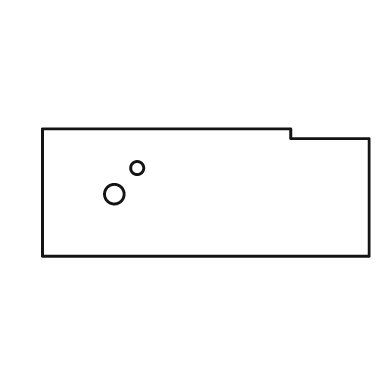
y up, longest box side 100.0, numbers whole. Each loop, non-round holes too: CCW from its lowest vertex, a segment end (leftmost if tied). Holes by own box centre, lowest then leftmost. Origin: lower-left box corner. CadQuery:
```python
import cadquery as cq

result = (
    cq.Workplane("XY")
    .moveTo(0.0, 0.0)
    .lineTo(100.0, 0.0)
    .lineTo(100.0, 36.0)
    .lineTo(76.0, 36.0)
    .lineTo(76.0, 39.0)
    .lineTo(0.0, 39.0)
    .close()
    .moveTo(22.0, 19.0)
    .circle(3.0)
    .moveTo(29.0, 27.0)
    .circle(2.0)
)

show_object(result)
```